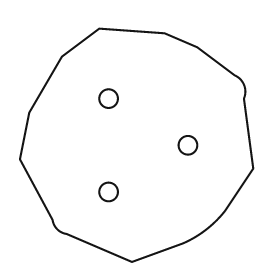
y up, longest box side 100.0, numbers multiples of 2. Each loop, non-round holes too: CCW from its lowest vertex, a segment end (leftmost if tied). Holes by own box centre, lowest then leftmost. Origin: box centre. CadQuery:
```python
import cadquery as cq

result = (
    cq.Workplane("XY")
    .moveTo(-2.0, -50.0)
    .lineTo(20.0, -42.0)
    .threePointArc((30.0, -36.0), (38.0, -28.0))
    .lineTo(50.0, -10.0)
    .lineTo(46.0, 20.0)
    .threePointArc((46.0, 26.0), (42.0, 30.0))
    .lineTo(26.0, 42.0)
    .lineTo(12.0, 48.0)
    .lineTo(-16.0, 50.0)
    .lineTo(-32.0, 38.0)
    .lineTo(-46.0, 14.0)
    .lineTo(-50.0, -6.0)
    .lineTo(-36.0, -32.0)
    .threePointArc((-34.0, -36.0), (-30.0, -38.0))
    .close()
    .moveTo(-12.0, -20.0)
    .circle(4.0)
    .moveTo(22.0, 0.0)
    .circle(4.0)
    .moveTo(-12.0, 20.0)
    .circle(4.0)
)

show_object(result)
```